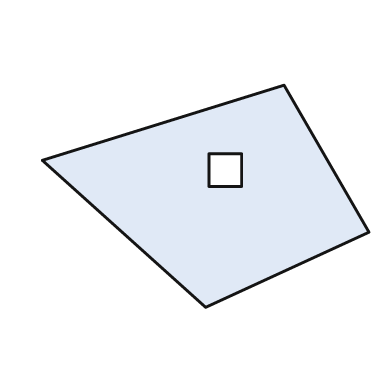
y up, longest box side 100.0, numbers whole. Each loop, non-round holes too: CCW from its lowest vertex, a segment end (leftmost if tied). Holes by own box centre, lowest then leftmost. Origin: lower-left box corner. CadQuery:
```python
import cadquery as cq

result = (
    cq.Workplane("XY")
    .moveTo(50.0, 0.0)
    .lineTo(100.0, 23.0)
    .lineTo(74.0, 68.0)
    .lineTo(0.0, 45.0)
    .close()
    .moveTo(51.0, 37.0)
    .lineTo(61.0, 37.0)
    .lineTo(61.0, 47.0)
    .lineTo(51.0, 47.0)
    .close()
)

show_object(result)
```